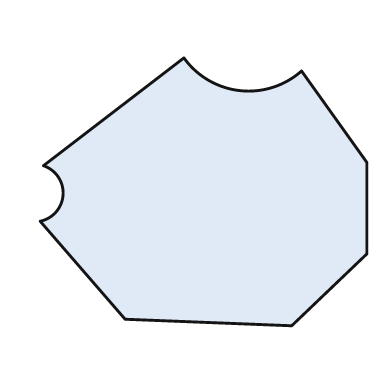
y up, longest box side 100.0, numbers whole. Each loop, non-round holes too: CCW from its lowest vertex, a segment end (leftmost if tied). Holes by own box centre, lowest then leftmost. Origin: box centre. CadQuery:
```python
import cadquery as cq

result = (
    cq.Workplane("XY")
    .moveTo(27.0, -41.0)
    .lineTo(50.0, -19.0)
    .lineTo(50.0, 9.0)
    .lineTo(30.0, 37.0)
    .threePointArc((11.0, 31.0), (-6.0, 41.0))
    .lineTo(-49.0, 8.0)
    .threePointArc((-43.0, -1.0), (-50.0, -9.0))
    .lineTo(-24.0, -39.0)
    .close()
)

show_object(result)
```